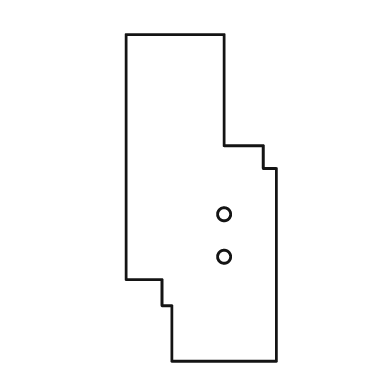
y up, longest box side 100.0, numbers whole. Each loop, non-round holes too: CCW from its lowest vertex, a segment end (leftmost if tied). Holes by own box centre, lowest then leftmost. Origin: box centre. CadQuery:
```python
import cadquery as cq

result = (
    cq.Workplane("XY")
    .moveTo(-9.0, -50.0)
    .lineTo(23.0, -50.0)
    .lineTo(23.0, 9.0)
    .lineTo(19.0, 9.0)
    .lineTo(19.0, 16.0)
    .lineTo(7.0, 16.0)
    .lineTo(7.0, 50.0)
    .lineTo(-23.0, 50.0)
    .lineTo(-23.0, -25.0)
    .lineTo(-12.0, -25.0)
    .lineTo(-12.0, -33.0)
    .lineTo(-9.0, -33.0)
    .close()
    .moveTo(7.0, -18.0)
    .circle(2.0)
    .moveTo(7.0, -5.0)
    .circle(2.0)
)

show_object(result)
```